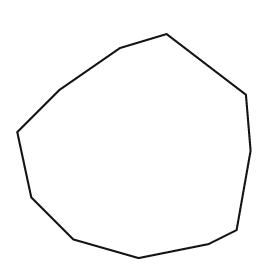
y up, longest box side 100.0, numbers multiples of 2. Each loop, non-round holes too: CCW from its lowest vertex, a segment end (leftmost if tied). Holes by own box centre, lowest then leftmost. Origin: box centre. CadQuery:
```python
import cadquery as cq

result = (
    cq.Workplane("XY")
    .moveTo(2.0, -48.0)
    .lineTo(32.0, -42.0)
    .lineTo(44.0, -36.0)
    .lineTo(50.0, -2.0)
    .lineTo(48.0, 22.0)
    .lineTo(14.0, 48.0)
    .lineTo(-6.0, 42.0)
    .lineTo(-32.0, 24.0)
    .lineTo(-50.0, 6.0)
    .lineTo(-44.0, -22.0)
    .lineTo(-26.0, -40.0)
    .close()
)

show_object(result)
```